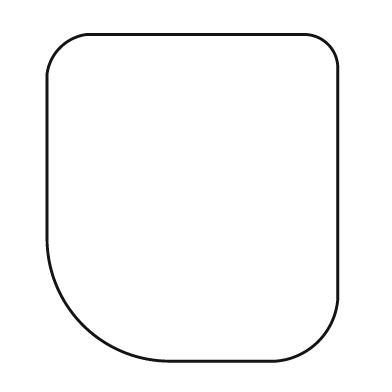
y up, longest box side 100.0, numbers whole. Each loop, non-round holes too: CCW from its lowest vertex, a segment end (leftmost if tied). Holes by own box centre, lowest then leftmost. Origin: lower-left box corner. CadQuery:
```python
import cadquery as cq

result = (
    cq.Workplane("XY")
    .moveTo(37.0, 0.0)
    .lineTo(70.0, 0.0)
    .threePointArc((83.0, 6.0), (89.0, 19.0))
    .lineTo(89.0, 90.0)
    .threePointArc((86.0, 97.0), (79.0, 100.0))
    .lineTo(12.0, 100.0)
    .threePointArc((4.0, 96.0), (0.0, 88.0))
    .lineTo(0.0, 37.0)
    .threePointArc((11.0, 11.0), (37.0, 0.0))
    .close()
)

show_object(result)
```